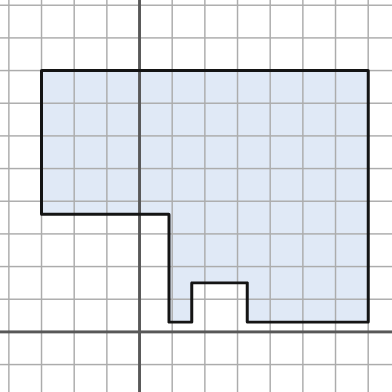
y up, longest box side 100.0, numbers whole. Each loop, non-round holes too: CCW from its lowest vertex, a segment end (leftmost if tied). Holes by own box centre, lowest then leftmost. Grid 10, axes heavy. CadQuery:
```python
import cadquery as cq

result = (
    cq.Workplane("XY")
    .moveTo(9.0, 3.0)
    .lineTo(16.0, 3.0)
    .lineTo(16.0, 15.0)
    .lineTo(33.0, 15.0)
    .lineTo(33.0, 3.0)
    .lineTo(70.0, 3.0)
    .lineTo(70.0, 80.0)
    .lineTo(-30.0, 80.0)
    .lineTo(-30.0, 36.0)
    .lineTo(9.0, 36.0)
    .close()
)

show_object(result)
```